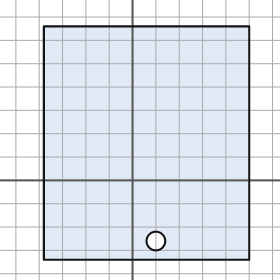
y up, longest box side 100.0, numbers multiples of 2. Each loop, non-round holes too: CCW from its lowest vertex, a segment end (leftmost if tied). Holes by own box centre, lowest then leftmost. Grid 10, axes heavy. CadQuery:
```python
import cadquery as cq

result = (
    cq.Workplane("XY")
    .moveTo(-38.0, -34.0)
    .lineTo(50.0, -34.0)
    .lineTo(50.0, 66.0)
    .lineTo(-38.0, 66.0)
    .close()
    .moveTo(10.0, -26.0)
    .circle(4.0)
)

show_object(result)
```